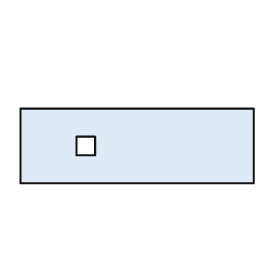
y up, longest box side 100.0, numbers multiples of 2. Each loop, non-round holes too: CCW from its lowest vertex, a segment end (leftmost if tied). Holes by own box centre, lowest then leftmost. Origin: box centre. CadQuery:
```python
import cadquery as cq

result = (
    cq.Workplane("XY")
    .moveTo(-50.0, -16.0)
    .lineTo(50.0, -16.0)
    .lineTo(50.0, 16.0)
    .lineTo(-50.0, 16.0)
    .close()
    .moveTo(-26.0, -4.0)
    .lineTo(-18.0, -4.0)
    .lineTo(-18.0, 4.0)
    .lineTo(-26.0, 4.0)
    .close()
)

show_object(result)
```